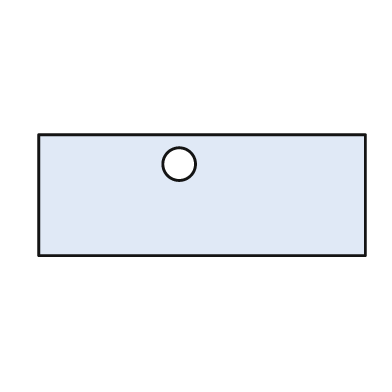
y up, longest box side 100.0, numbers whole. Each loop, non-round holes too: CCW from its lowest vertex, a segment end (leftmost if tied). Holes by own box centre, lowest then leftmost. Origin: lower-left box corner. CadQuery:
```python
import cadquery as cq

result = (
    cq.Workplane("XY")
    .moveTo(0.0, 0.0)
    .lineTo(100.0, 0.0)
    .lineTo(100.0, 37.0)
    .lineTo(0.0, 37.0)
    .close()
    .moveTo(43.0, 28.0)
    .circle(5.0)
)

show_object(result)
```